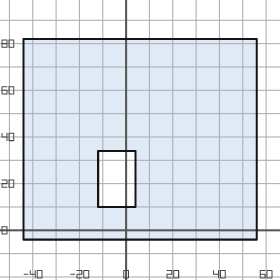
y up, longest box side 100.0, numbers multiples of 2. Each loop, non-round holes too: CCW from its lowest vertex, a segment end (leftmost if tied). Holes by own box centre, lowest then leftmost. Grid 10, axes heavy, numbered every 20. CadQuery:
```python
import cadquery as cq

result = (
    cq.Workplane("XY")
    .moveTo(-44.0, -4.0)
    .lineTo(56.0, -4.0)
    .lineTo(56.0, 82.0)
    .lineTo(-44.0, 82.0)
    .close()
    .moveTo(-12.0, 10.0)
    .lineTo(4.0, 10.0)
    .lineTo(4.0, 34.0)
    .lineTo(-12.0, 34.0)
    .close()
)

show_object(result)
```